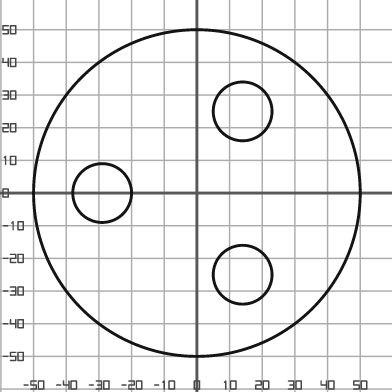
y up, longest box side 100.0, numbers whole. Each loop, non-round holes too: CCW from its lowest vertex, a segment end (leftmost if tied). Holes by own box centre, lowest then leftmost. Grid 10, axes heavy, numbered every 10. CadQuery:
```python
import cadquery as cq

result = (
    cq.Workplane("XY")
    .moveTo(0.0, 0.0)
    .circle(50.0)
    .moveTo(14.0, -25.0)
    .circle(9.0)
    .moveTo(-29.0, 0.0)
    .circle(9.0)
    .moveTo(14.0, 25.0)
    .circle(9.0)
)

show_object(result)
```